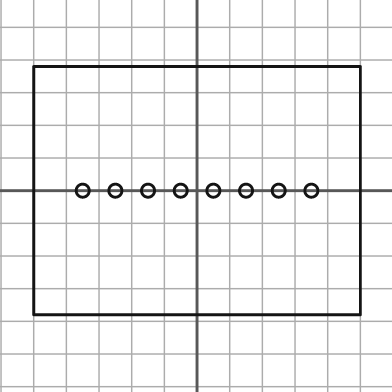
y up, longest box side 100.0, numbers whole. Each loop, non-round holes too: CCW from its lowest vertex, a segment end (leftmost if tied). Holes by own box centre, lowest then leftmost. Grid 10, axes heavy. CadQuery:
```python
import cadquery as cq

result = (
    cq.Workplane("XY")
    .moveTo(-50.0, -38.0)
    .lineTo(50.0, -38.0)
    .lineTo(50.0, 38.0)
    .lineTo(-50.0, 38.0)
    .close()
    .moveTo(-35.0, 0.0)
    .circle(2.0)
    .moveTo(-25.0, 0.0)
    .circle(2.0)
    .moveTo(-15.0, 0.0)
    .circle(2.0)
    .moveTo(-5.0, 0.0)
    .circle(2.0)
    .moveTo(5.0, 0.0)
    .circle(2.0)
    .moveTo(15.0, 0.0)
    .circle(2.0)
    .moveTo(25.0, 0.0)
    .circle(2.0)
    .moveTo(35.0, 0.0)
    .circle(2.0)
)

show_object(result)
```